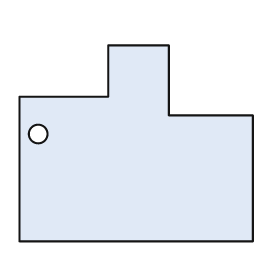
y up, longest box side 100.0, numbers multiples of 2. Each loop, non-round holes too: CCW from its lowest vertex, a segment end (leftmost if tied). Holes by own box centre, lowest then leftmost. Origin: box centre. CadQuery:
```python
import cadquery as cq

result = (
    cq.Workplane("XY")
    .moveTo(-50.0, -42.0)
    .lineTo(50.0, -42.0)
    .lineTo(50.0, 12.0)
    .lineTo(14.0, 12.0)
    .lineTo(14.0, 42.0)
    .lineTo(-12.0, 42.0)
    .lineTo(-12.0, 20.0)
    .lineTo(-50.0, 20.0)
    .close()
    .moveTo(-42.0, 4.0)
    .circle(4.0)
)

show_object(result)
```